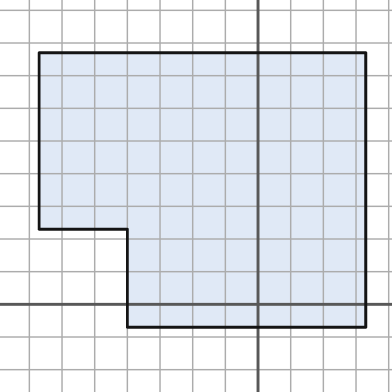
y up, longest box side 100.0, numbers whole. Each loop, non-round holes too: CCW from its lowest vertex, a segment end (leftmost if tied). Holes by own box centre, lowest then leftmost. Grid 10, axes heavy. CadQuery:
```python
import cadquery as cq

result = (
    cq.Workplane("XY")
    .moveTo(-40.0, -7.0)
    .lineTo(33.0, -7.0)
    .lineTo(33.0, 77.0)
    .lineTo(-67.0, 77.0)
    .lineTo(-67.0, 23.0)
    .lineTo(-40.0, 23.0)
    .close()
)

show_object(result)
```